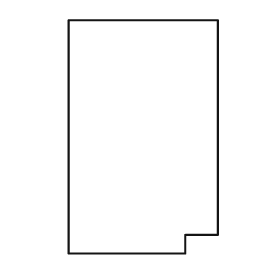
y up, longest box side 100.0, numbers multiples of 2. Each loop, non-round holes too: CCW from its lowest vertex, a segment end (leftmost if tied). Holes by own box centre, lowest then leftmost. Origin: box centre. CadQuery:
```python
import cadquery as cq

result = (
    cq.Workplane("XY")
    .moveTo(-32.0, -50.0)
    .lineTo(18.0, -50.0)
    .lineTo(18.0, -42.0)
    .lineTo(32.0, -42.0)
    .lineTo(32.0, 50.0)
    .lineTo(-32.0, 50.0)
    .close()
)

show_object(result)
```